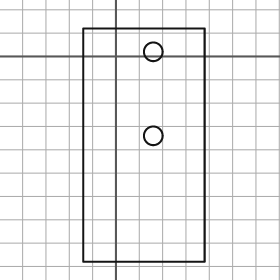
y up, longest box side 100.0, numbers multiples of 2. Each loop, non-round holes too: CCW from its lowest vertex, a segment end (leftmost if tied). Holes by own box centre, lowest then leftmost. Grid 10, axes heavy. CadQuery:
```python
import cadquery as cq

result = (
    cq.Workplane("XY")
    .moveTo(-14.0, -88.0)
    .lineTo(38.0, -88.0)
    .lineTo(38.0, 12.0)
    .lineTo(-14.0, 12.0)
    .close()
    .moveTo(16.0, -34.0)
    .circle(4.0)
    .moveTo(16.0, 2.0)
    .circle(4.0)
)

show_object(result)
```